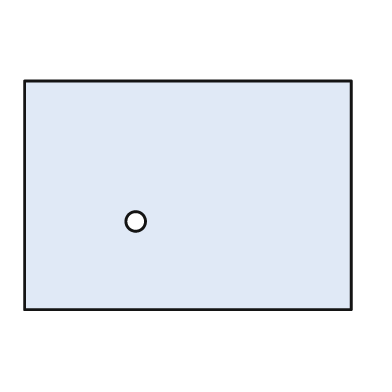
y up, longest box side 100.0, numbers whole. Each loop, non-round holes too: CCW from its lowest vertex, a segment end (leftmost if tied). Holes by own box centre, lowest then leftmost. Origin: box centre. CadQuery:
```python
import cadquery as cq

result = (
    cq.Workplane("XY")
    .moveTo(-50.0, -35.0)
    .lineTo(50.0, -35.0)
    .lineTo(50.0, 35.0)
    .lineTo(-50.0, 35.0)
    .close()
    .moveTo(-16.0, -8.0)
    .circle(3.0)
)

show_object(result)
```